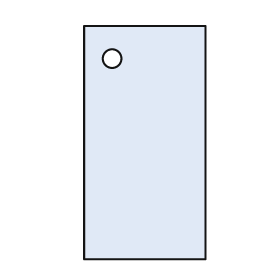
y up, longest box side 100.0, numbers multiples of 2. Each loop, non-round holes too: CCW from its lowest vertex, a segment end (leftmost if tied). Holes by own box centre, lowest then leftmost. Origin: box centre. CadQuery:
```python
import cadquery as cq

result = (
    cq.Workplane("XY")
    .moveTo(-26.0, -50.0)
    .lineTo(26.0, -50.0)
    .lineTo(26.0, 50.0)
    .lineTo(-26.0, 50.0)
    .close()
    .moveTo(-14.0, 36.0)
    .circle(4.0)
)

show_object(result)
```